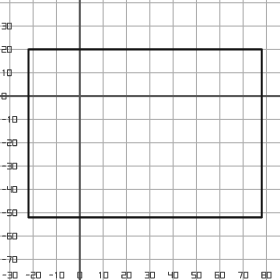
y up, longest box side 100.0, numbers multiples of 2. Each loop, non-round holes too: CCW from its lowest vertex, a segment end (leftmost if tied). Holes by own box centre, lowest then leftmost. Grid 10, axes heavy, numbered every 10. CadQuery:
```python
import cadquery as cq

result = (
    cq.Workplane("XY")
    .moveTo(-22.0, -52.0)
    .lineTo(78.0, -52.0)
    .lineTo(78.0, 20.0)
    .lineTo(-22.0, 20.0)
    .close()
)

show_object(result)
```